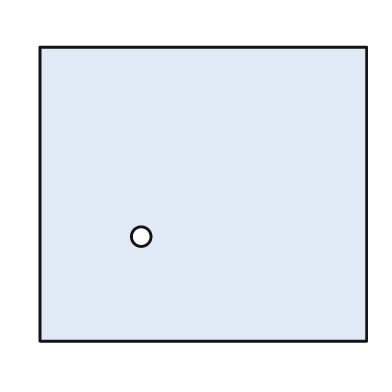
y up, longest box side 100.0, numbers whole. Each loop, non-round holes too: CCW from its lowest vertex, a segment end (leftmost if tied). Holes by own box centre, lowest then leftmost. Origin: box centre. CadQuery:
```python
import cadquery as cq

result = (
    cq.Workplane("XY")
    .moveTo(-50.0, -45.0)
    .lineTo(50.0, -45.0)
    .lineTo(50.0, 45.0)
    .lineTo(-50.0, 45.0)
    .close()
    .moveTo(-19.0, -13.0)
    .circle(3.0)
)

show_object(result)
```